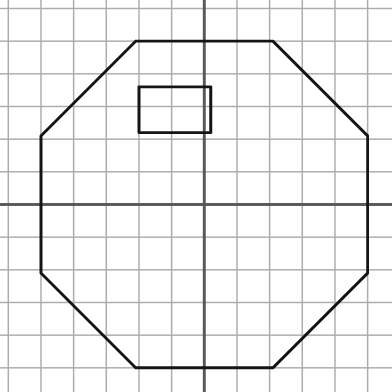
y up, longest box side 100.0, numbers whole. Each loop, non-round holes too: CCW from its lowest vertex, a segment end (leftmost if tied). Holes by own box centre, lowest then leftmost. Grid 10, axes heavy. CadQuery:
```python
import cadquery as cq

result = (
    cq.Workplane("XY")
    .moveTo(-21.0, -50.0)
    .lineTo(21.0, -50.0)
    .lineTo(50.0, -21.0)
    .lineTo(50.0, 21.0)
    .lineTo(21.0, 50.0)
    .lineTo(-21.0, 50.0)
    .lineTo(-50.0, 21.0)
    .lineTo(-50.0, -21.0)
    .close()
    .moveTo(-20.0, 22.0)
    .lineTo(2.0, 22.0)
    .lineTo(2.0, 36.0)
    .lineTo(-20.0, 36.0)
    .close()
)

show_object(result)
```